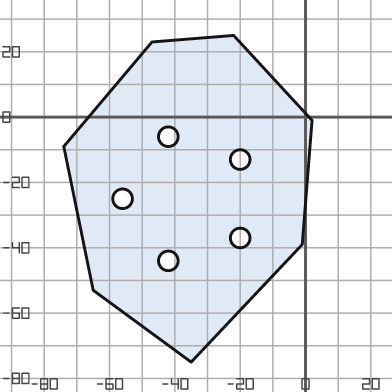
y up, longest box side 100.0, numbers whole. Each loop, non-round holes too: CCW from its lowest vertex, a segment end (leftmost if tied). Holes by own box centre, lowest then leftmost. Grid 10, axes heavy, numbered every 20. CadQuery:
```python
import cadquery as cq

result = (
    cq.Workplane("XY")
    .moveTo(-35.0, -75.0)
    .lineTo(-1.0, -39.0)
    .lineTo(2.0, -1.0)
    .lineTo(-22.0, 25.0)
    .lineTo(-47.0, 23.0)
    .lineTo(-74.0, -9.0)
    .lineTo(-65.0, -53.0)
    .close()
    .moveTo(-42.0, -44.0)
    .circle(3.0)
    .moveTo(-20.0, -37.0)
    .circle(3.0)
    .moveTo(-56.0, -25.0)
    .circle(3.0)
    .moveTo(-20.0, -13.0)
    .circle(3.0)
    .moveTo(-42.0, -6.0)
    .circle(3.0)
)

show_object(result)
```